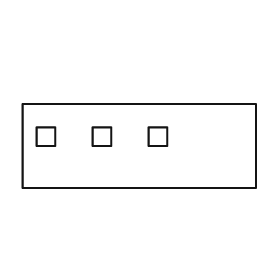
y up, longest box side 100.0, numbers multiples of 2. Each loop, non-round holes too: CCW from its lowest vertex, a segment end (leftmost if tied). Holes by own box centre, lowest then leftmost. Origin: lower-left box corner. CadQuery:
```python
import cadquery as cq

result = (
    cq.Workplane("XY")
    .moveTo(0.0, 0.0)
    .lineTo(100.0, 0.0)
    .lineTo(100.0, 36.0)
    .lineTo(0.0, 36.0)
    .close()
    .moveTo(6.0, 18.0)
    .lineTo(14.0, 18.0)
    .lineTo(14.0, 26.0)
    .lineTo(6.0, 26.0)
    .close()
    .moveTo(30.0, 18.0)
    .lineTo(38.0, 18.0)
    .lineTo(38.0, 26.0)
    .lineTo(30.0, 26.0)
    .close()
    .moveTo(54.0, 18.0)
    .lineTo(62.0, 18.0)
    .lineTo(62.0, 26.0)
    .lineTo(54.0, 26.0)
    .close()
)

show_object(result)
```